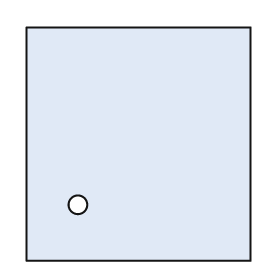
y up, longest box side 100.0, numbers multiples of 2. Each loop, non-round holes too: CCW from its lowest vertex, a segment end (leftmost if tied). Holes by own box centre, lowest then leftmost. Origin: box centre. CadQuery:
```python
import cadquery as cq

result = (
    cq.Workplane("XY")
    .moveTo(-48.0, -50.0)
    .lineTo(48.0, -50.0)
    .lineTo(48.0, 50.0)
    .lineTo(-48.0, 50.0)
    .close()
    .moveTo(-26.0, -26.0)
    .circle(4.0)
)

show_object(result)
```